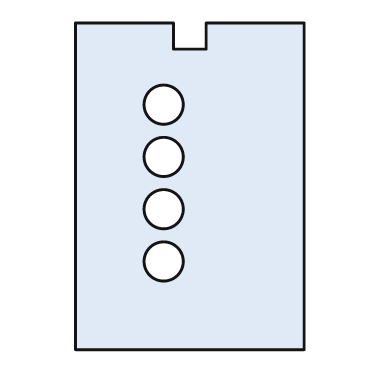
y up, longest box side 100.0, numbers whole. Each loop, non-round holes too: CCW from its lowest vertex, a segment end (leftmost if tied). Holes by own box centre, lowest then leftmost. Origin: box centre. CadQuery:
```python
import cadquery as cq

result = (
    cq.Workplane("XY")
    .moveTo(-35.0, -50.0)
    .lineTo(35.0, -50.0)
    .lineTo(35.0, 50.0)
    .lineTo(5.0, 50.0)
    .lineTo(5.0, 42.0)
    .lineTo(-5.0, 42.0)
    .lineTo(-5.0, 50.0)
    .lineTo(-35.0, 50.0)
    .close()
    .moveTo(-8.0, -23.0)
    .circle(6.0)
    .moveTo(-8.0, -7.0)
    .circle(6.0)
    .moveTo(-8.0, 9.0)
    .circle(6.0)
    .moveTo(-8.0, 25.0)
    .circle(6.0)
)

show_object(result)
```